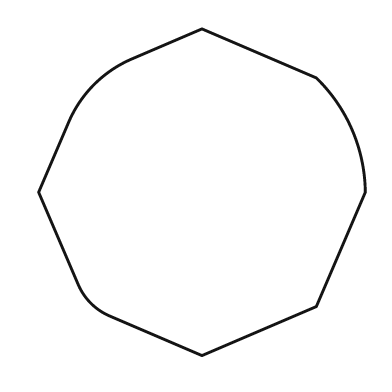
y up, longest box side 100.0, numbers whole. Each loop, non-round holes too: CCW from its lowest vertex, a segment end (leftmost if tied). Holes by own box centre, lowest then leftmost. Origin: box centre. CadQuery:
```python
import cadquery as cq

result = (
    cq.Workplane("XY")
    .moveTo(0.0, -50.0)
    .lineTo(35.0, -35.0)
    .lineTo(50.0, 0.0)
    .threePointArc((46.0, 19.0), (35.0, 35.0))
    .lineTo(0.0, 50.0)
    .lineTo(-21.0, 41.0)
    .threePointArc((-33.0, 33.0), (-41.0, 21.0))
    .lineTo(-50.0, 0.0)
    .lineTo(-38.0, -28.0)
    .threePointArc((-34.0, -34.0), (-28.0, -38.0))
    .close()
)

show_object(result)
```